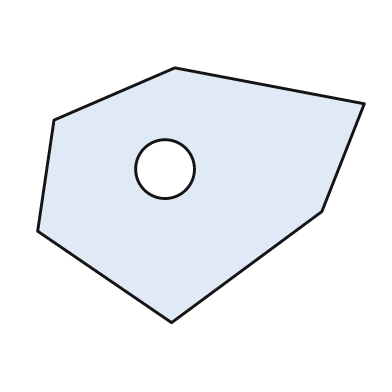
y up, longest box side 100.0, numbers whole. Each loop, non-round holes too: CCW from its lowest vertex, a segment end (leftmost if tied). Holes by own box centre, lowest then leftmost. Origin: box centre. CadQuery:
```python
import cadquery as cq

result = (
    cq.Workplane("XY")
    .moveTo(-9.0, -39.0)
    .lineTo(37.0, -5.0)
    .lineTo(50.0, 28.0)
    .lineTo(-8.0, 39.0)
    .lineTo(-45.0, 23.0)
    .lineTo(-50.0, -11.0)
    .close()
    .moveTo(-11.0, 8.0)
    .circle(9.0)
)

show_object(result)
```